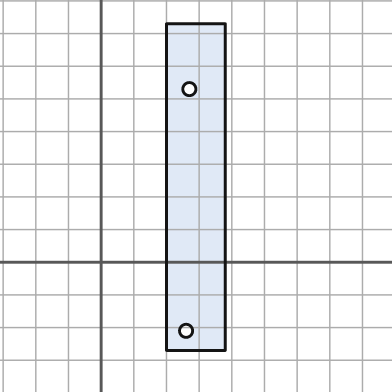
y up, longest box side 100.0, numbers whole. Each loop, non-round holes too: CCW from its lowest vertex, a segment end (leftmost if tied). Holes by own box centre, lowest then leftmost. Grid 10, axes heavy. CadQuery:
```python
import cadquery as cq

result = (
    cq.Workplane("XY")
    .moveTo(20.0, -27.0)
    .lineTo(38.0, -27.0)
    .lineTo(38.0, 73.0)
    .lineTo(20.0, 73.0)
    .close()
    .moveTo(26.0, -21.0)
    .circle(2.0)
    .moveTo(27.0, 53.0)
    .circle(2.0)
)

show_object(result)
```